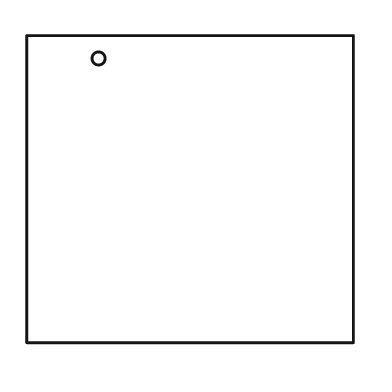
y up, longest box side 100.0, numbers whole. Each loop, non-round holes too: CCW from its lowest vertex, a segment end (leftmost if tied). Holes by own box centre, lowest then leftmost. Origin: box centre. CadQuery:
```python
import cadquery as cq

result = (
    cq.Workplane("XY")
    .moveTo(-50.0, -47.0)
    .lineTo(50.0, -47.0)
    .lineTo(50.0, 47.0)
    .lineTo(-50.0, 47.0)
    .close()
    .moveTo(-28.0, 40.0)
    .circle(2.0)
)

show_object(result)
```